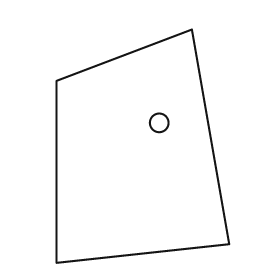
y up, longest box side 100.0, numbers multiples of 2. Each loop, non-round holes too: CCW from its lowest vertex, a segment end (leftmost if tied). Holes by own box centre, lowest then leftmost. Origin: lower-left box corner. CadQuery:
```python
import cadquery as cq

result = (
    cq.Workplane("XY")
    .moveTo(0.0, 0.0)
    .lineTo(74.0, 8.0)
    .lineTo(58.0, 100.0)
    .lineTo(0.0, 78.0)
    .close()
    .moveTo(44.0, 60.0)
    .circle(4.0)
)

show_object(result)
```